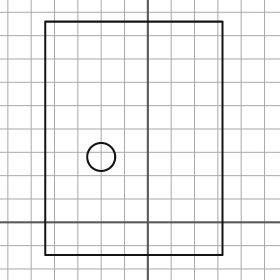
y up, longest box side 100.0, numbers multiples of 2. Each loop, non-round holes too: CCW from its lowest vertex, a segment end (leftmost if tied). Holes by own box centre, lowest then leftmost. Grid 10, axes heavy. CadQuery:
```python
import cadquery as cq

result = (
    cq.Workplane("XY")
    .moveTo(-44.0, -14.0)
    .lineTo(32.0, -14.0)
    .lineTo(32.0, 86.0)
    .lineTo(-44.0, 86.0)
    .close()
    .moveTo(-20.0, 28.0)
    .circle(6.0)
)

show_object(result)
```